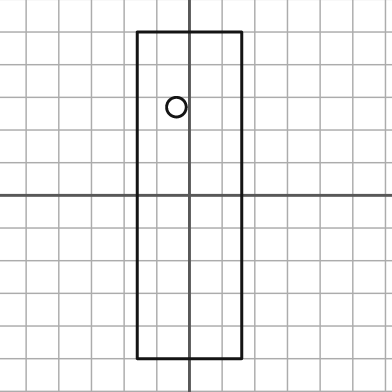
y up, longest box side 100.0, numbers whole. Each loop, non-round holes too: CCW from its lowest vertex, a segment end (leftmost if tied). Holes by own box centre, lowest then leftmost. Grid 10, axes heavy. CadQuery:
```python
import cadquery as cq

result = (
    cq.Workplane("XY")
    .moveTo(-16.0, -50.0)
    .lineTo(16.0, -50.0)
    .lineTo(16.0, 50.0)
    .lineTo(-16.0, 50.0)
    .close()
    .moveTo(-4.0, 27.0)
    .circle(3.0)
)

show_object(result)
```